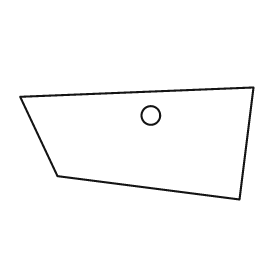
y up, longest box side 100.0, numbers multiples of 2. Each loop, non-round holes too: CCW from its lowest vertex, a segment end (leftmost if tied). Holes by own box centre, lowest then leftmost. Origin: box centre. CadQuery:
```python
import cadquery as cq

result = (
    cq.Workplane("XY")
    .moveTo(44.0, -24.0)
    .lineTo(50.0, 24.0)
    .lineTo(-50.0, 20.0)
    .lineTo(-34.0, -14.0)
    .close()
    .moveTo(6.0, 12.0)
    .circle(4.0)
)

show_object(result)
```